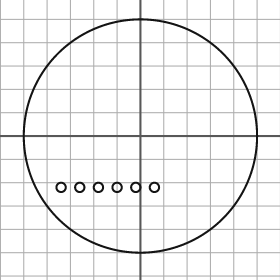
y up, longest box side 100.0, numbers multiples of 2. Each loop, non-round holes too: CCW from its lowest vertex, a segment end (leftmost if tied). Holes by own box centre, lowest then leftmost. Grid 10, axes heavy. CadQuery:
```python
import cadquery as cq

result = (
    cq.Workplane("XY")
    .moveTo(0.0, 0.0)
    .circle(50.0)
    .moveTo(-34.0, -22.0)
    .circle(2.0)
    .moveTo(-26.0, -22.0)
    .circle(2.0)
    .moveTo(-18.0, -22.0)
    .circle(2.0)
    .moveTo(-10.0, -22.0)
    .circle(2.0)
    .moveTo(-2.0, -22.0)
    .circle(2.0)
    .moveTo(6.0, -22.0)
    .circle(2.0)
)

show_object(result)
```